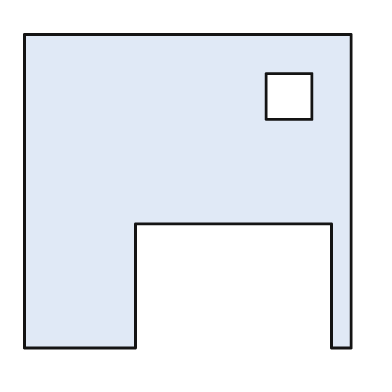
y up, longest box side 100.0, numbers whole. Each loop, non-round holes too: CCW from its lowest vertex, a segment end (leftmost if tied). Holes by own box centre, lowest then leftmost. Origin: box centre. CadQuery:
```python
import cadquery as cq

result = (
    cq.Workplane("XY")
    .moveTo(-50.0, -48.0)
    .lineTo(-16.0, -48.0)
    .lineTo(-16.0, -10.0)
    .lineTo(44.0, -10.0)
    .lineTo(44.0, -48.0)
    .lineTo(50.0, -48.0)
    .lineTo(50.0, 48.0)
    .lineTo(-50.0, 48.0)
    .close()
    .moveTo(24.0, 22.0)
    .lineTo(38.0, 22.0)
    .lineTo(38.0, 36.0)
    .lineTo(24.0, 36.0)
    .close()
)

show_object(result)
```